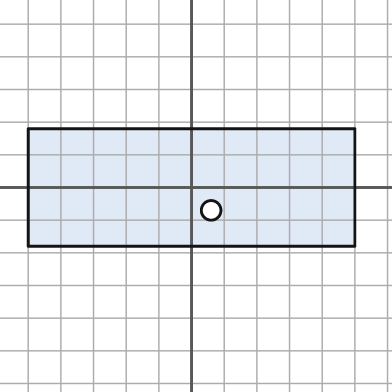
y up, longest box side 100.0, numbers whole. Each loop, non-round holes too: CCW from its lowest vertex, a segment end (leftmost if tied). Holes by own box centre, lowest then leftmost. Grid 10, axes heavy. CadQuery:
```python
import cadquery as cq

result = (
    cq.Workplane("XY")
    .moveTo(-50.0, -18.0)
    .lineTo(50.0, -18.0)
    .lineTo(50.0, 18.0)
    .lineTo(-50.0, 18.0)
    .close()
    .moveTo(6.0, -7.0)
    .circle(3.0)
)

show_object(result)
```